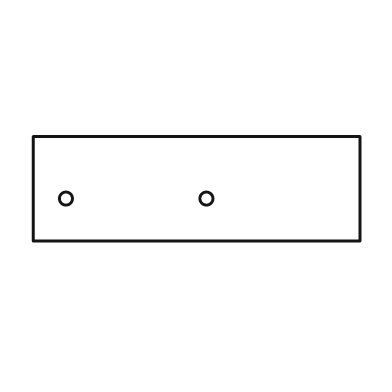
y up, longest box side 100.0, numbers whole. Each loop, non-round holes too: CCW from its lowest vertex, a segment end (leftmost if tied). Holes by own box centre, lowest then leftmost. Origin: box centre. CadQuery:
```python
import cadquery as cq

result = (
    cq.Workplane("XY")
    .moveTo(-50.0, -16.0)
    .lineTo(50.0, -16.0)
    .lineTo(50.0, 16.0)
    .lineTo(-50.0, 16.0)
    .close()
    .moveTo(-40.0, -3.0)
    .circle(2.0)
    .moveTo(3.0, -3.0)
    .circle(2.0)
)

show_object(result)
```